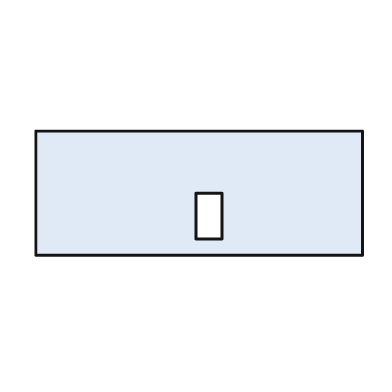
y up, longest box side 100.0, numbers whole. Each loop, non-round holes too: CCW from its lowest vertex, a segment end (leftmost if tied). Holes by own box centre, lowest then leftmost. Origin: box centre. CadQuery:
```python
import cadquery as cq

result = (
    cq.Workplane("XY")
    .moveTo(-50.0, -19.0)
    .lineTo(50.0, -19.0)
    .lineTo(50.0, 19.0)
    .lineTo(-50.0, 19.0)
    .close()
    .moveTo(-1.0, -14.0)
    .lineTo(7.0, -14.0)
    .lineTo(7.0, 0.0)
    .lineTo(-1.0, 0.0)
    .close()
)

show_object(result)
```